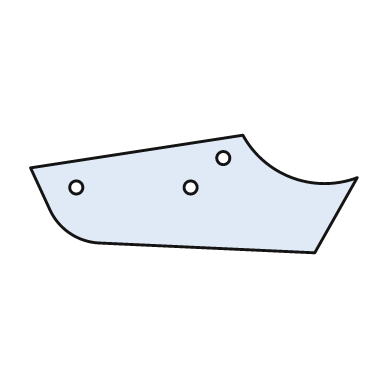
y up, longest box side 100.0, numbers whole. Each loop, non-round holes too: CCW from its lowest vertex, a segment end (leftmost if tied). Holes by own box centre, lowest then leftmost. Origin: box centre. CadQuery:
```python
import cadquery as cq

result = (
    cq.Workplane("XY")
    .moveTo(37.0, -18.0)
    .lineTo(50.0, 5.0)
    .threePointArc((30.0, 5.0), (15.0, 18.0))
    .lineTo(-50.0, 8.0)
    .lineTo(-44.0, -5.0)
    .threePointArc((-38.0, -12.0), (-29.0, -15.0))
    .close()
    .moveTo(-36.0, 2.0)
    .circle(2.0)
    .moveTo(-1.0, 2.0)
    .circle(2.0)
    .moveTo(9.0, 11.0)
    .circle(2.0)
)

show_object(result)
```